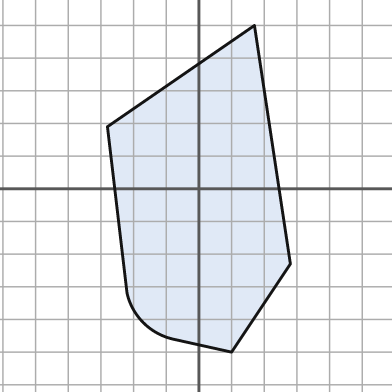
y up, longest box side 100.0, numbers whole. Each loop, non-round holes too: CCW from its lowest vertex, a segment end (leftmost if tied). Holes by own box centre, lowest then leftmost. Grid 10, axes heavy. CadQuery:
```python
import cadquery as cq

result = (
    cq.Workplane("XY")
    .moveTo(10.0, -50.0)
    .lineTo(28.0, -23.0)
    .lineTo(17.0, 50.0)
    .lineTo(-28.0, 19.0)
    .lineTo(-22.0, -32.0)
    .threePointArc((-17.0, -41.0), (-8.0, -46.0))
    .close()
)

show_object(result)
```